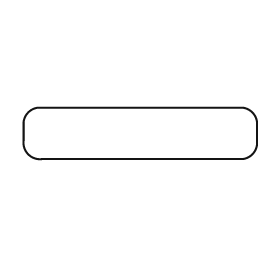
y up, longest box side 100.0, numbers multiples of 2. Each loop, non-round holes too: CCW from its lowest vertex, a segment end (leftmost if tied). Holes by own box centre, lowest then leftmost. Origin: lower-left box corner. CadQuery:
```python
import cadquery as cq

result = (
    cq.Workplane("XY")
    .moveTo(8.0, 0.0)
    .lineTo(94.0, 0.0)
    .threePointArc((98.0, 2.0), (100.0, 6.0))
    .lineTo(100.0, 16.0)
    .threePointArc((98.0, 20.0), (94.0, 22.0))
    .lineTo(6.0, 22.0)
    .threePointArc((2.0, 20.0), (0.0, 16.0))
    .lineTo(0.0, 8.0)
    .threePointArc((2.0, 2.0), (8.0, 0.0))
    .close()
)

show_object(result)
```